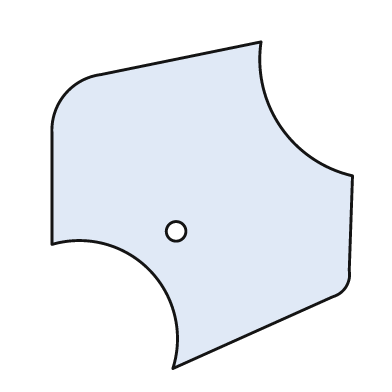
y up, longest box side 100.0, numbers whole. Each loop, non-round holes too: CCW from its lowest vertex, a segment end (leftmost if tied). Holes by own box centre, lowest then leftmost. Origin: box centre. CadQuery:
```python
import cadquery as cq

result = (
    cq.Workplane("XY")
    .moveTo(-9.0, -50.0)
    .lineTo(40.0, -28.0)
    .threePointArc((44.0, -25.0), (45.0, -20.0))
    .lineTo(46.0, 9.0)
    .threePointArc((24.0, 24.0), (18.0, 50.0))
    .lineTo(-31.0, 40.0)
    .threePointArc((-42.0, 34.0), (-46.0, 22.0))
    .lineTo(-46.0, -12.0)
    .threePointArc((-16.0, -20.0), (-9.0, -50.0))
    .close()
    .moveTo(-8.0, -8.0)
    .circle(3.0)
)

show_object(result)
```